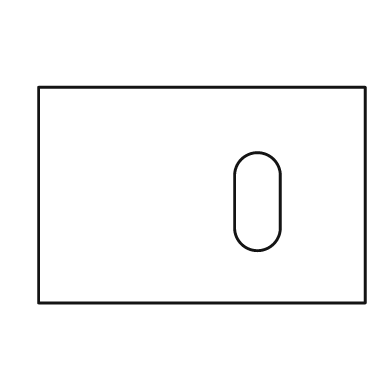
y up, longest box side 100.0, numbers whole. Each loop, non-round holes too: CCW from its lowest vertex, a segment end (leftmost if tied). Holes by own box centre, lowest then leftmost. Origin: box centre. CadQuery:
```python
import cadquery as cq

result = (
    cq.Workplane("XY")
    .moveTo(-50.0, -33.0)
    .lineTo(50.0, -33.0)
    .lineTo(50.0, 33.0)
    .lineTo(-50.0, 33.0)
    .close()
    .moveTo(10.0, -10.0)
    .threePointArc((17.0, -17.0), (24.0, -10.0))
    .lineTo(24.0, 6.0)
    .threePointArc((17.0, 13.0), (10.0, 6.0))
    .close()
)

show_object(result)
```